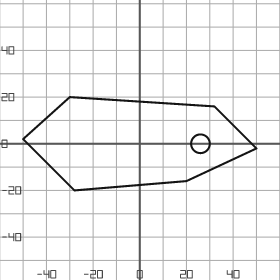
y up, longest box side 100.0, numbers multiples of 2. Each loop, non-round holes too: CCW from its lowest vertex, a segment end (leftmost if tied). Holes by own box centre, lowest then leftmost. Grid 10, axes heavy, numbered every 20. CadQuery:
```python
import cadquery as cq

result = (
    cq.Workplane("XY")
    .moveTo(-28.0, -20.0)
    .lineTo(20.0, -16.0)
    .lineTo(50.0, -2.0)
    .lineTo(32.0, 16.0)
    .lineTo(-30.0, 20.0)
    .lineTo(-50.0, 2.0)
    .close()
    .moveTo(26.0, 0.0)
    .circle(4.0)
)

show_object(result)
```